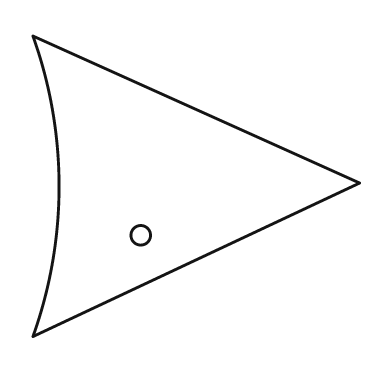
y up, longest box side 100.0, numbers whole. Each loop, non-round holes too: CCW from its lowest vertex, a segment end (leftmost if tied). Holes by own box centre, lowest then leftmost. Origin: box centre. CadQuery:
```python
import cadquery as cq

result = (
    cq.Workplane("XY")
    .moveTo(-50.0, -46.0)
    .lineTo(50.0, 1.0)
    .lineTo(-50.0, 46.0)
    .threePointArc((-42.0, 0.0), (-50.0, -46.0))
    .close()
    .moveTo(-17.0, -15.0)
    .circle(3.0)
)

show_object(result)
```